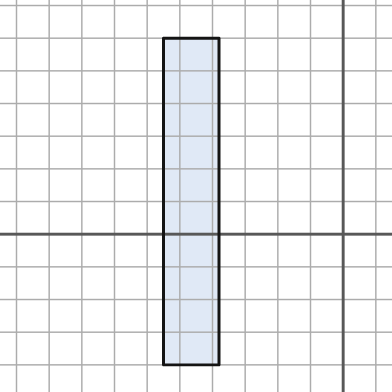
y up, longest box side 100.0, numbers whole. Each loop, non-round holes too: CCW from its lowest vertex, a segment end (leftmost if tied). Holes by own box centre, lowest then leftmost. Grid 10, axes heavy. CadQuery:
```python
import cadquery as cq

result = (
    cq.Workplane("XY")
    .moveTo(-55.0, -40.0)
    .lineTo(-38.0, -40.0)
    .lineTo(-38.0, 60.0)
    .lineTo(-55.0, 60.0)
    .close()
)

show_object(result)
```